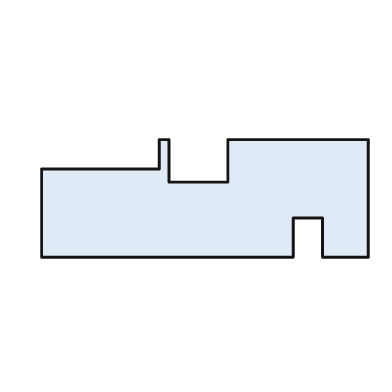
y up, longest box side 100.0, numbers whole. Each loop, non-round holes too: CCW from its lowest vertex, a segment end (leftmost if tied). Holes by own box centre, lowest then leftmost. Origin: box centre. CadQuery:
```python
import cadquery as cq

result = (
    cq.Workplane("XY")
    .moveTo(-50.0, -18.0)
    .lineTo(27.0, -18.0)
    .lineTo(27.0, -6.0)
    .lineTo(36.0, -6.0)
    .lineTo(36.0, -18.0)
    .lineTo(50.0, -18.0)
    .lineTo(50.0, 18.0)
    .lineTo(7.0, 18.0)
    .lineTo(7.0, 5.0)
    .lineTo(-11.0, 5.0)
    .lineTo(-11.0, 18.0)
    .lineTo(-14.0, 18.0)
    .lineTo(-14.0, 9.0)
    .lineTo(-50.0, 9.0)
    .close()
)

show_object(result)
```